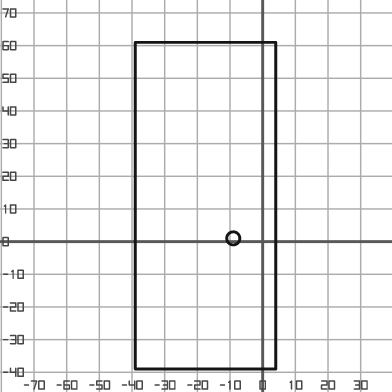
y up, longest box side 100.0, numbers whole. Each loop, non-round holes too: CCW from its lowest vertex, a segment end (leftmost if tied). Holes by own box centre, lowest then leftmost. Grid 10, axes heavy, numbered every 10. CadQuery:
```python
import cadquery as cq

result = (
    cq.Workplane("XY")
    .moveTo(-39.0, -39.0)
    .lineTo(4.0, -39.0)
    .lineTo(4.0, 61.0)
    .lineTo(-39.0, 61.0)
    .close()
    .moveTo(-9.0, 1.0)
    .circle(2.0)
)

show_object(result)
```